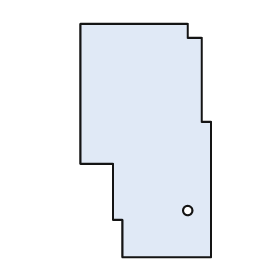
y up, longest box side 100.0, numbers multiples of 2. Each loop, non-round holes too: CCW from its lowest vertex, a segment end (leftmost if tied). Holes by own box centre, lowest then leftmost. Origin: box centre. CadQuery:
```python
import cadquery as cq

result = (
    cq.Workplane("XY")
    .moveTo(-10.0, -50.0)
    .lineTo(28.0, -50.0)
    .lineTo(28.0, 8.0)
    .lineTo(24.0, 8.0)
    .lineTo(24.0, 44.0)
    .lineTo(18.0, 44.0)
    .lineTo(18.0, 50.0)
    .lineTo(-28.0, 50.0)
    .lineTo(-28.0, -10.0)
    .lineTo(-14.0, -10.0)
    .lineTo(-14.0, -34.0)
    .lineTo(-10.0, -34.0)
    .close()
    .moveTo(18.0, -30.0)
    .circle(2.0)
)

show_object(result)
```